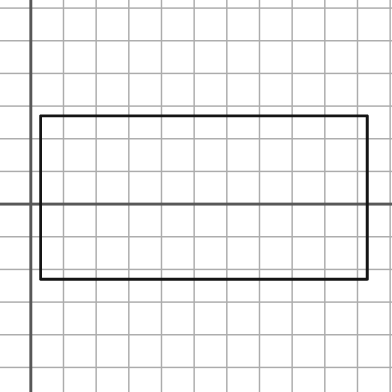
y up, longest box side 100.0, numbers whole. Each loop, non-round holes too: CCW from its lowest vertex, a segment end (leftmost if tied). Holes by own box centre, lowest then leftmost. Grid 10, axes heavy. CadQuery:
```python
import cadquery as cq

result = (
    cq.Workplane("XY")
    .moveTo(3.0, -23.0)
    .lineTo(103.0, -23.0)
    .lineTo(103.0, 27.0)
    .lineTo(3.0, 27.0)
    .close()
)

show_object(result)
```